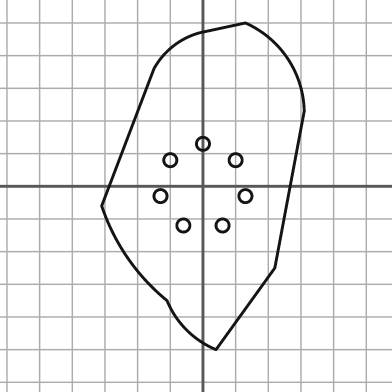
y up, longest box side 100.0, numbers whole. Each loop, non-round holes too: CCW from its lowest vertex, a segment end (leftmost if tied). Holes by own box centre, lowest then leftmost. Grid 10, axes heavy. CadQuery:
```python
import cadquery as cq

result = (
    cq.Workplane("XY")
    .moveTo(4.0, -50.0)
    .lineTo(22.0, -25.0)
    .lineTo(31.0, 23.0)
    .threePointArc((26.0, 39.0), (13.0, 50.0))
    .lineTo(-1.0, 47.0)
    .threePointArc((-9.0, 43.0), (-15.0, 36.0))
    .lineTo(-31.0, -6.0)
    .threePointArc((-23.0, -22.0), (-11.0, -35.0))
    .threePointArc((-5.0, -44.0), (4.0, -50.0))
    .close()
    .moveTo(-6.0, -12.0)
    .circle(2.0)
    .moveTo(6.0, -12.0)
    .circle(2.0)
    .moveTo(-13.0, -3.0)
    .circle(2.0)
    .moveTo(13.0, -3.0)
    .circle(2.0)
    .moveTo(-10.0, 8.0)
    .circle(2.0)
    .moveTo(10.0, 8.0)
    .circle(2.0)
    .moveTo(0.0, 13.0)
    .circle(2.0)
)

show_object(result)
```